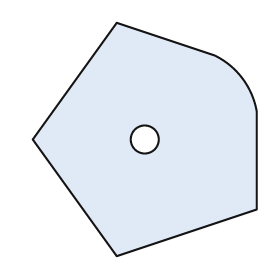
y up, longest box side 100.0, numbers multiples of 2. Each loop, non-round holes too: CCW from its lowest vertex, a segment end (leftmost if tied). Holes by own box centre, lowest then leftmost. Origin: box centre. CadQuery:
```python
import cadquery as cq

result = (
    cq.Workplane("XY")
    .moveTo(-12.0, -50.0)
    .lineTo(48.0, -30.0)
    .lineTo(48.0, 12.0)
    .threePointArc((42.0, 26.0), (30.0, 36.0))
    .lineTo(-12.0, 50.0)
    .lineTo(-48.0, 0.0)
    .close()
    .moveTo(0.0, 0.0)
    .circle(6.0)
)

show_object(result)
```